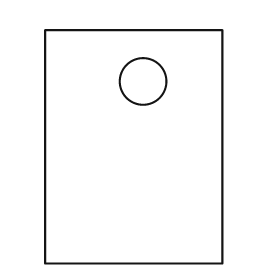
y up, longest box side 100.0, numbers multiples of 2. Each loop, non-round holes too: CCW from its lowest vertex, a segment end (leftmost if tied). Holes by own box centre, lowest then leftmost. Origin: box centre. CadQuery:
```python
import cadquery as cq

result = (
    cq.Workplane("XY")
    .moveTo(-38.0, -50.0)
    .lineTo(38.0, -50.0)
    .lineTo(38.0, 50.0)
    .lineTo(-38.0, 50.0)
    .close()
    .moveTo(4.0, 28.0)
    .circle(10.0)
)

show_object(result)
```